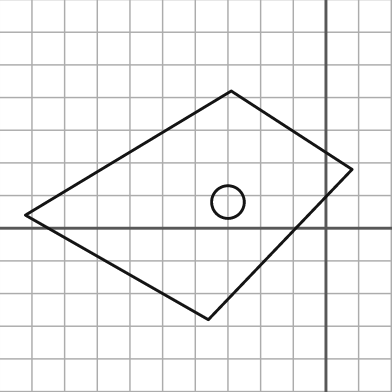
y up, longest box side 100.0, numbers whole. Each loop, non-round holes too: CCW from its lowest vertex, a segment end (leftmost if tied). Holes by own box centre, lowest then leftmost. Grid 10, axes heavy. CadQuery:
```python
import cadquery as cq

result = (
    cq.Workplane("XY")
    .moveTo(-36.0, -28.0)
    .lineTo(8.0, 18.0)
    .lineTo(-29.0, 42.0)
    .lineTo(-92.0, 4.0)
    .close()
    .moveTo(-30.0, 8.0)
    .circle(5.0)
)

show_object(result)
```